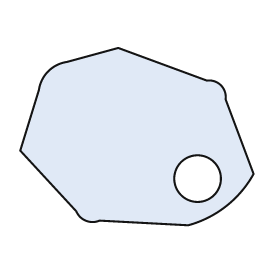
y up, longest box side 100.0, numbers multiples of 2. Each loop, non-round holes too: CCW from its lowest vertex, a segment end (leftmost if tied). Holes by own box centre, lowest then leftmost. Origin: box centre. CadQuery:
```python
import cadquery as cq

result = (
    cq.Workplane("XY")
    .moveTo(22.0, -38.0)
    .threePointArc((38.0, -30.0), (50.0, -16.0))
    .lineTo(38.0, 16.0)
    .threePointArc((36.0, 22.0), (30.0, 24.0))
    .lineTo(-8.0, 38.0)
    .lineTo(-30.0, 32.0)
    .threePointArc((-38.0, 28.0), (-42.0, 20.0))
    .lineTo(-50.0, -6.0)
    .lineTo(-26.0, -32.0)
    .threePointArc((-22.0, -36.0), (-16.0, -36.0))
    .close()
    .moveTo(26.0, -18.0)
    .circle(10.0)
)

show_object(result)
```